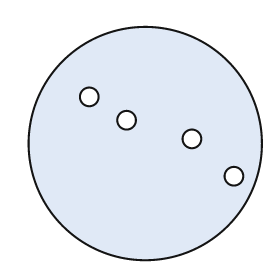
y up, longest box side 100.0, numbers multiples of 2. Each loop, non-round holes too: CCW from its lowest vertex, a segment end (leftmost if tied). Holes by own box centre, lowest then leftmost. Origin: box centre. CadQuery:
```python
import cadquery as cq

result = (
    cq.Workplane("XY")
    .moveTo(0.0, 0.0)
    .circle(50.0)
    .moveTo(38.0, -14.0)
    .circle(4.0)
    .moveTo(20.0, 2.0)
    .circle(4.0)
    .moveTo(-8.0, 10.0)
    .circle(4.0)
    .moveTo(-24.0, 20.0)
    .circle(4.0)
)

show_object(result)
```